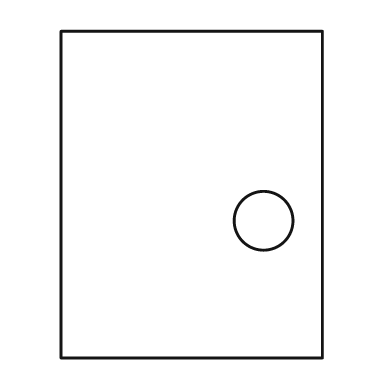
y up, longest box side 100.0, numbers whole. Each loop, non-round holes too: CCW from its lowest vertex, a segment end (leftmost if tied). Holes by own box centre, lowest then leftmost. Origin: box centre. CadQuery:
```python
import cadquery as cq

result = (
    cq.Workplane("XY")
    .moveTo(-40.0, -50.0)
    .lineTo(40.0, -50.0)
    .lineTo(40.0, 50.0)
    .lineTo(-40.0, 50.0)
    .close()
    .moveTo(22.0, -8.0)
    .circle(9.0)
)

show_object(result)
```